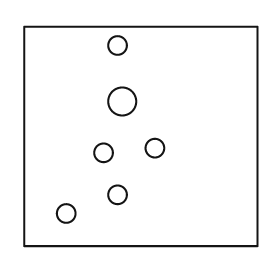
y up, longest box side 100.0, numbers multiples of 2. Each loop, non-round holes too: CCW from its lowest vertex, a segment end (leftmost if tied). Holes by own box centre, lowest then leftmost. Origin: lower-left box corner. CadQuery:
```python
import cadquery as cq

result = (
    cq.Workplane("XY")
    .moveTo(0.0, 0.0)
    .lineTo(100.0, 0.0)
    .lineTo(100.0, 94.0)
    .lineTo(0.0, 94.0)
    .close()
    .moveTo(18.0, 14.0)
    .circle(4.0)
    .moveTo(40.0, 22.0)
    .circle(4.0)
    .moveTo(34.0, 40.0)
    .circle(4.0)
    .moveTo(56.0, 42.0)
    .circle(4.0)
    .moveTo(42.0, 62.0)
    .circle(6.0)
    .moveTo(40.0, 86.0)
    .circle(4.0)
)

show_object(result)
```